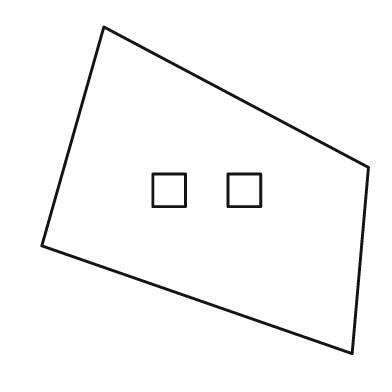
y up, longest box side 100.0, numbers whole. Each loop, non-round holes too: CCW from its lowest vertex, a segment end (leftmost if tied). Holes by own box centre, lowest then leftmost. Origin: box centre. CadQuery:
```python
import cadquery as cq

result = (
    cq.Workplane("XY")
    .moveTo(45.0, -50.0)
    .lineTo(50.0, 7.0)
    .lineTo(-31.0, 50.0)
    .lineTo(-50.0, -17.0)
    .close()
    .moveTo(-16.0, -5.0)
    .lineTo(-6.0, -5.0)
    .lineTo(-6.0, 5.0)
    .lineTo(-16.0, 5.0)
    .close()
    .moveTo(7.0, -5.0)
    .lineTo(17.0, -5.0)
    .lineTo(17.0, 5.0)
    .lineTo(7.0, 5.0)
    .close()
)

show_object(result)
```